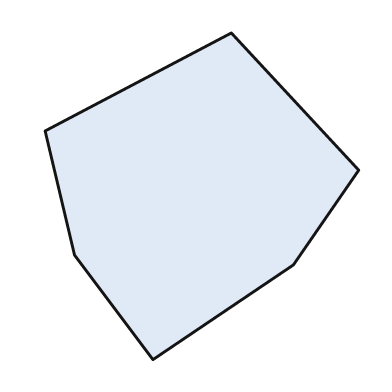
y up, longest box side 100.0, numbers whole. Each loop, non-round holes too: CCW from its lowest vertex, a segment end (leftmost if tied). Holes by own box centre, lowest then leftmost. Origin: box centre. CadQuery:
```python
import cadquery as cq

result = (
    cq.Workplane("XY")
    .moveTo(-15.0, -50.0)
    .lineTo(28.0, -21.0)
    .lineTo(48.0, 8.0)
    .lineTo(9.0, 50.0)
    .lineTo(-48.0, 20.0)
    .lineTo(-39.0, -18.0)
    .close()
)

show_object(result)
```